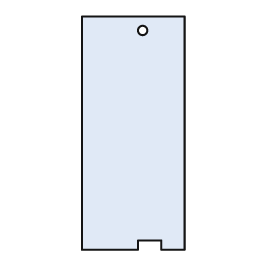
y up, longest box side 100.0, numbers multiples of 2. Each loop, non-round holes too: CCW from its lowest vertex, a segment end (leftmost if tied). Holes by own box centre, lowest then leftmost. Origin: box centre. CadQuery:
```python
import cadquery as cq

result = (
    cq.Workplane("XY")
    .moveTo(-22.0, -50.0)
    .lineTo(2.0, -50.0)
    .lineTo(2.0, -46.0)
    .lineTo(12.0, -46.0)
    .lineTo(12.0, -50.0)
    .lineTo(22.0, -50.0)
    .lineTo(22.0, 50.0)
    .lineTo(-22.0, 50.0)
    .close()
    .moveTo(4.0, 44.0)
    .circle(2.0)
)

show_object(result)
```